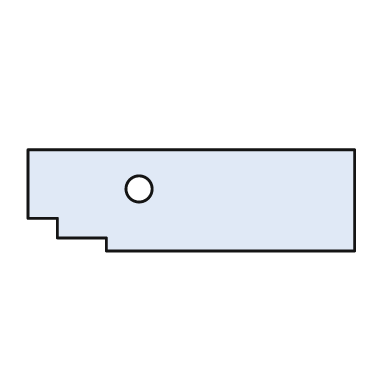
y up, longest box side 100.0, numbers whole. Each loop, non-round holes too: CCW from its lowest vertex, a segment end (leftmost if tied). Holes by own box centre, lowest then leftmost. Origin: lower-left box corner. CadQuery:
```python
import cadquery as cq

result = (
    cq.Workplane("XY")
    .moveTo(24.0, 0.0)
    .lineTo(100.0, 0.0)
    .lineTo(100.0, 31.0)
    .lineTo(0.0, 31.0)
    .lineTo(0.0, 10.0)
    .lineTo(9.0, 10.0)
    .lineTo(9.0, 4.0)
    .lineTo(24.0, 4.0)
    .close()
    .moveTo(34.0, 19.0)
    .circle(4.0)
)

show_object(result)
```